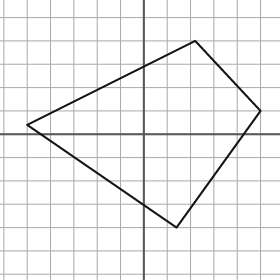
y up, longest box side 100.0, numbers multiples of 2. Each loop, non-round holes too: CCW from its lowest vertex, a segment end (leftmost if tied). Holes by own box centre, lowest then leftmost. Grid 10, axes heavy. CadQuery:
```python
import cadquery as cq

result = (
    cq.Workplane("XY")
    .moveTo(14.0, -40.0)
    .lineTo(50.0, 10.0)
    .lineTo(22.0, 40.0)
    .lineTo(-50.0, 4.0)
    .close()
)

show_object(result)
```